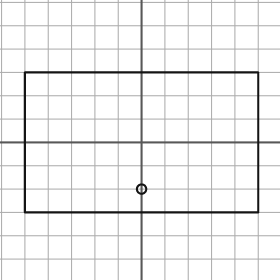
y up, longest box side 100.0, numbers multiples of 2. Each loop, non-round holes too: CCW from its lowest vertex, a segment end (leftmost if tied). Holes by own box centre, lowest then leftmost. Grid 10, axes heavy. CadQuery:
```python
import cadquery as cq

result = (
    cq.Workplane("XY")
    .moveTo(-50.0, -30.0)
    .lineTo(50.0, -30.0)
    .lineTo(50.0, 30.0)
    .lineTo(-50.0, 30.0)
    .close()
    .moveTo(0.0, -20.0)
    .circle(2.0)
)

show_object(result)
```